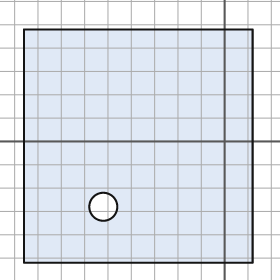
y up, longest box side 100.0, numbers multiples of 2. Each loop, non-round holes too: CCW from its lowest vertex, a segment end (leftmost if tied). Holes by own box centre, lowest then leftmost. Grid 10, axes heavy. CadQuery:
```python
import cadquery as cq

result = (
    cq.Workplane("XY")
    .moveTo(-86.0, -52.0)
    .lineTo(12.0, -52.0)
    .lineTo(12.0, 48.0)
    .lineTo(-86.0, 48.0)
    .close()
    .moveTo(-52.0, -28.0)
    .circle(6.0)
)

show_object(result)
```